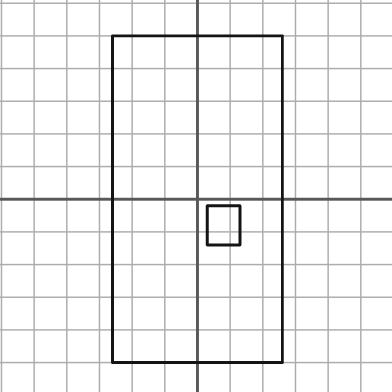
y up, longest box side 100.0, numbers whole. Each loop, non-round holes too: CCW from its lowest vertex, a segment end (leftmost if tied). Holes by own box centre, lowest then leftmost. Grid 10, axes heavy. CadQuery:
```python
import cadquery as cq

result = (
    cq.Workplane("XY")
    .moveTo(-26.0, -50.0)
    .lineTo(26.0, -50.0)
    .lineTo(26.0, 50.0)
    .lineTo(-26.0, 50.0)
    .close()
    .moveTo(3.0, -14.0)
    .lineTo(13.0, -14.0)
    .lineTo(13.0, -2.0)
    .lineTo(3.0, -2.0)
    .close()
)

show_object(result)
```